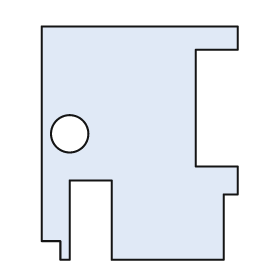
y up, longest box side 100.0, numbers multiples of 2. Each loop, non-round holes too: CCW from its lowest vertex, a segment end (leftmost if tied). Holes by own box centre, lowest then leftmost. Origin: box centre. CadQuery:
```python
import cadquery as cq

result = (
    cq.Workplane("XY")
    .moveTo(-34.0, -50.0)
    .lineTo(-30.0, -50.0)
    .lineTo(-30.0, -16.0)
    .lineTo(-12.0, -16.0)
    .lineTo(-12.0, -50.0)
    .lineTo(36.0, -50.0)
    .lineTo(36.0, -22.0)
    .lineTo(42.0, -22.0)
    .lineTo(42.0, -10.0)
    .lineTo(24.0, -10.0)
    .lineTo(24.0, 40.0)
    .lineTo(42.0, 40.0)
    .lineTo(42.0, 50.0)
    .lineTo(-42.0, 50.0)
    .lineTo(-42.0, -42.0)
    .lineTo(-34.0, -42.0)
    .close()
    .moveTo(-30.0, 4.0)
    .circle(8.0)
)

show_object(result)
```